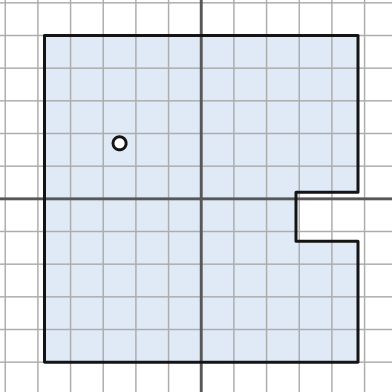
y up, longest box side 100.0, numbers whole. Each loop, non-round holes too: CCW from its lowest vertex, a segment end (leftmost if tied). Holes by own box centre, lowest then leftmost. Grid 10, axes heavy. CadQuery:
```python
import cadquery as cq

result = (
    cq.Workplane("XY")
    .moveTo(-48.0, -50.0)
    .lineTo(48.0, -50.0)
    .lineTo(48.0, -13.0)
    .lineTo(29.0, -13.0)
    .lineTo(29.0, 2.0)
    .lineTo(48.0, 2.0)
    .lineTo(48.0, 50.0)
    .lineTo(-48.0, 50.0)
    .close()
    .moveTo(-25.0, 17.0)
    .circle(2.0)
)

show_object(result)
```